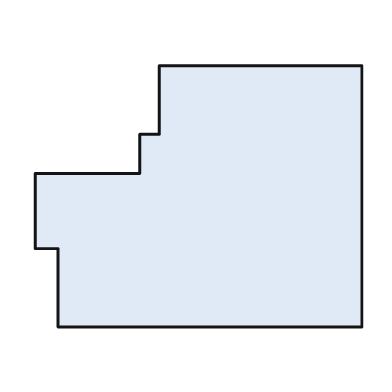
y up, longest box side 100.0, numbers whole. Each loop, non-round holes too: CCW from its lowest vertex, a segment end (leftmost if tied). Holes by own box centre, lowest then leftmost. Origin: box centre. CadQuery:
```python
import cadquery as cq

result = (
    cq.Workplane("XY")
    .moveTo(-43.0, -40.0)
    .lineTo(50.0, -40.0)
    .lineTo(50.0, 40.0)
    .lineTo(-12.0, 40.0)
    .lineTo(-12.0, 19.0)
    .lineTo(-18.0, 19.0)
    .lineTo(-18.0, 7.0)
    .lineTo(-50.0, 7.0)
    .lineTo(-50.0, -16.0)
    .lineTo(-43.0, -16.0)
    .close()
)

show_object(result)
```